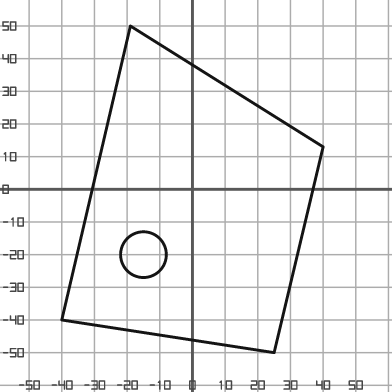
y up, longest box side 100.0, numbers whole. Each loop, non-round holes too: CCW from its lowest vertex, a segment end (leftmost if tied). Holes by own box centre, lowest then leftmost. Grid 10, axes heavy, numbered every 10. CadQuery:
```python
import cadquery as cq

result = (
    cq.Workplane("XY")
    .moveTo(25.0, -50.0)
    .lineTo(40.0, 13.0)
    .lineTo(-19.0, 50.0)
    .lineTo(-40.0, -40.0)
    .close()
    .moveTo(-15.0, -20.0)
    .circle(7.0)
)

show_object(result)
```